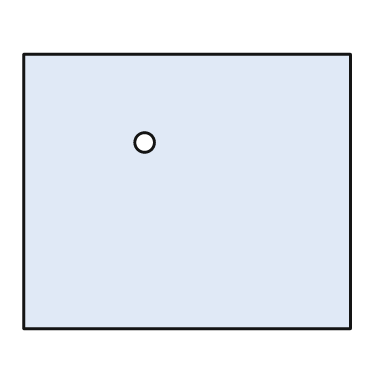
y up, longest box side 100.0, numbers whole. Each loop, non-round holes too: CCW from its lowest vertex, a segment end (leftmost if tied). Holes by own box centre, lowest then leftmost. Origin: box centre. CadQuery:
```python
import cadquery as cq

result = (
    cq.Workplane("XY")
    .moveTo(-50.0, -42.0)
    .lineTo(50.0, -42.0)
    .lineTo(50.0, 42.0)
    .lineTo(-50.0, 42.0)
    .close()
    .moveTo(-13.0, 15.0)
    .circle(3.0)
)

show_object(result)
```